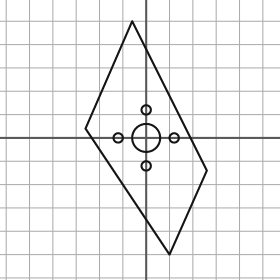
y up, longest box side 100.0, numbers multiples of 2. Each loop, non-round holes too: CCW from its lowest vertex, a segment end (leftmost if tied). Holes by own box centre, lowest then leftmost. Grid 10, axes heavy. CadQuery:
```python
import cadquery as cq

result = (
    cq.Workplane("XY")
    .moveTo(10.0, -50.0)
    .lineTo(26.0, -14.0)
    .lineTo(-6.0, 50.0)
    .lineTo(-26.0, 4.0)
    .close()
    .moveTo(0.0, -12.0)
    .circle(2.0)
    .moveTo(-12.0, 0.0)
    .circle(2.0)
    .moveTo(0.0, 0.0)
    .circle(6.0)
    .moveTo(12.0, 0.0)
    .circle(2.0)
    .moveTo(0.0, 12.0)
    .circle(2.0)
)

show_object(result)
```